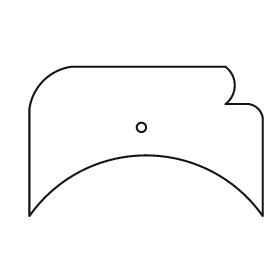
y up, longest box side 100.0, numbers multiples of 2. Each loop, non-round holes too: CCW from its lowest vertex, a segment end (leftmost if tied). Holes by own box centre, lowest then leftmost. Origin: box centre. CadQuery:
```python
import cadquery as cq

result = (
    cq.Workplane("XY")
    .moveTo(-50.0, -32.0)
    .threePointArc((0.0, -6.0), (50.0, -32.0))
    .lineTo(50.0, 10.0)
    .threePointArc((48.0, 14.0), (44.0, 16.0))
    .lineTo(34.0, 16.0)
    .threePointArc((38.0, 24.0), (34.0, 32.0))
    .lineTo(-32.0, 32.0)
    .threePointArc((-44.0, 26.0), (-50.0, 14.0))
    .close()
    .moveTo(-2.0, 6.0)
    .circle(2.0)
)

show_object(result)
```